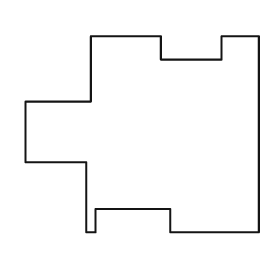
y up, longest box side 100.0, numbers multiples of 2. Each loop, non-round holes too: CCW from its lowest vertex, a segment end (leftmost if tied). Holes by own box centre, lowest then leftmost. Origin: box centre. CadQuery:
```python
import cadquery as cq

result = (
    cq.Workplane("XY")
    .moveTo(-24.0, -42.0)
    .lineTo(-20.0, -42.0)
    .lineTo(-20.0, -32.0)
    .lineTo(12.0, -32.0)
    .lineTo(12.0, -42.0)
    .lineTo(50.0, -42.0)
    .lineTo(50.0, 42.0)
    .lineTo(34.0, 42.0)
    .lineTo(34.0, 32.0)
    .lineTo(8.0, 32.0)
    .lineTo(8.0, 42.0)
    .lineTo(-22.0, 42.0)
    .lineTo(-22.0, 14.0)
    .lineTo(-50.0, 14.0)
    .lineTo(-50.0, -12.0)
    .lineTo(-24.0, -12.0)
    .close()
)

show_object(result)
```